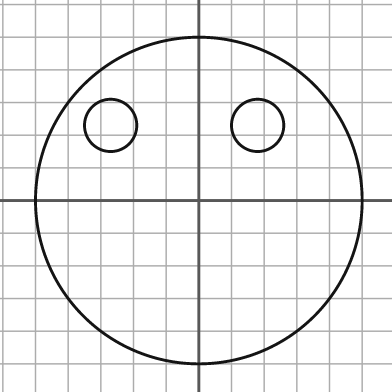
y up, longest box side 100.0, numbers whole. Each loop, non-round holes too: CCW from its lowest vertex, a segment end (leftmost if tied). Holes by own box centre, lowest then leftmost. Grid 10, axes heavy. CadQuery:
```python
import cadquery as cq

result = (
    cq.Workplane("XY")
    .moveTo(0.0, 0.0)
    .circle(50.0)
    .moveTo(-27.0, 23.0)
    .circle(8.0)
    .moveTo(18.0, 23.0)
    .circle(8.0)
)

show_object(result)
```